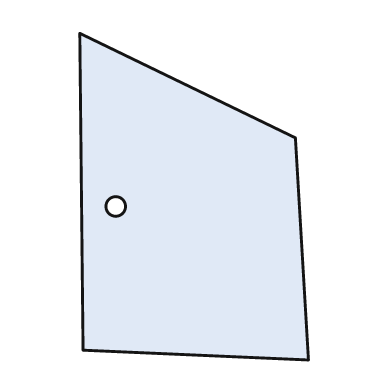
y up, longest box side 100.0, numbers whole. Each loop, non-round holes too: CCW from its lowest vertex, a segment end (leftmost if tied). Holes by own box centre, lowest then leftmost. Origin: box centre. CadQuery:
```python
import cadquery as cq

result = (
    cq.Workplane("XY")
    .moveTo(35.0, -50.0)
    .lineTo(31.0, 18.0)
    .lineTo(-35.0, 50.0)
    .lineTo(-34.0, -47.0)
    .close()
    .moveTo(-24.0, -3.0)
    .circle(3.0)
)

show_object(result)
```